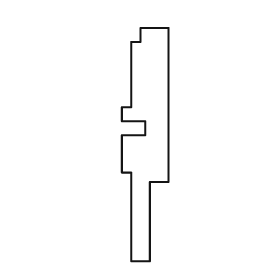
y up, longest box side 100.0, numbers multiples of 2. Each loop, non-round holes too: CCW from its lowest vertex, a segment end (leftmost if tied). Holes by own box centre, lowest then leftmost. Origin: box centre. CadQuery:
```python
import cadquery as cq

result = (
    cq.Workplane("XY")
    .moveTo(-6.0, -50.0)
    .lineTo(2.0, -50.0)
    .lineTo(2.0, -16.0)
    .lineTo(10.0, -16.0)
    .lineTo(10.0, 50.0)
    .lineTo(-2.0, 50.0)
    .lineTo(-2.0, 44.0)
    .lineTo(-6.0, 44.0)
    .lineTo(-6.0, 16.0)
    .lineTo(-10.0, 16.0)
    .lineTo(-10.0, 10.0)
    .lineTo(0.0, 10.0)
    .lineTo(0.0, 4.0)
    .lineTo(-10.0, 4.0)
    .lineTo(-10.0, -12.0)
    .lineTo(-6.0, -12.0)
    .close()
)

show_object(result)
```